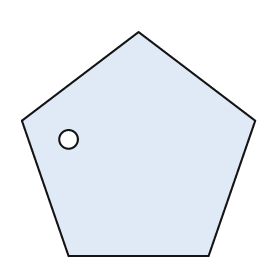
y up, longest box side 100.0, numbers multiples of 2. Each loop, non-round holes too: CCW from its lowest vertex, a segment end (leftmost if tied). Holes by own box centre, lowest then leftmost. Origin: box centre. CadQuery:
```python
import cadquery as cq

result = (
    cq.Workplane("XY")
    .moveTo(-30.0, -48.0)
    .lineTo(30.0, -48.0)
    .lineTo(50.0, 10.0)
    .lineTo(0.0, 48.0)
    .lineTo(-50.0, 10.0)
    .close()
    .moveTo(-30.0, 2.0)
    .circle(4.0)
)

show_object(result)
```